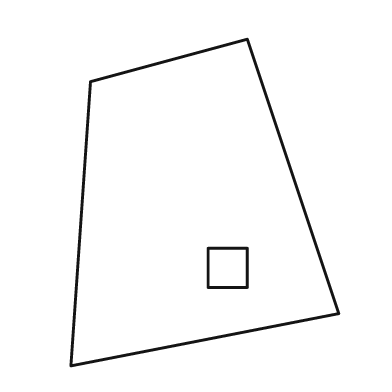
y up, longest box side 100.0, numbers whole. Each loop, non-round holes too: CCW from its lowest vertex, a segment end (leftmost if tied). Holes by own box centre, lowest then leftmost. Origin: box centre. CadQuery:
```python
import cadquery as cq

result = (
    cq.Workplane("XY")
    .moveTo(-41.0, -50.0)
    .lineTo(41.0, -34.0)
    .lineTo(13.0, 50.0)
    .lineTo(-35.0, 37.0)
    .close()
    .moveTo(1.0, -26.0)
    .lineTo(13.0, -26.0)
    .lineTo(13.0, -14.0)
    .lineTo(1.0, -14.0)
    .close()
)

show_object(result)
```